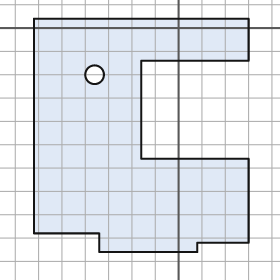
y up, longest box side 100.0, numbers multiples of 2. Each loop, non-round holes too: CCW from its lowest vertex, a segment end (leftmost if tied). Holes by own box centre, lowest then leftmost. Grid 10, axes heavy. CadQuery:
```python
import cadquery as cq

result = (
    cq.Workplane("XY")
    .moveTo(-34.0, -96.0)
    .lineTo(8.0, -96.0)
    .lineTo(8.0, -92.0)
    .lineTo(30.0, -92.0)
    .lineTo(30.0, -56.0)
    .lineTo(-16.0, -56.0)
    .lineTo(-16.0, -14.0)
    .lineTo(30.0, -14.0)
    .lineTo(30.0, 4.0)
    .lineTo(-62.0, 4.0)
    .lineTo(-62.0, -88.0)
    .lineTo(-34.0, -88.0)
    .close()
    .moveTo(-36.0, -20.0)
    .circle(4.0)
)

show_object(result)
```